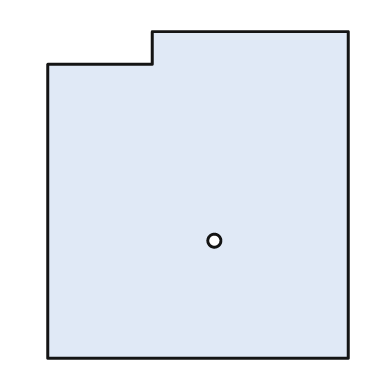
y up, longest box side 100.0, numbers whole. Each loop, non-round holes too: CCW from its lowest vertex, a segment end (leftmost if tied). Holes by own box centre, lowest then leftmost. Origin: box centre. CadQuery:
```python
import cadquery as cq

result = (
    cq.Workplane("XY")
    .moveTo(-46.0, -50.0)
    .lineTo(46.0, -50.0)
    .lineTo(46.0, 50.0)
    .lineTo(-14.0, 50.0)
    .lineTo(-14.0, 40.0)
    .lineTo(-46.0, 40.0)
    .close()
    .moveTo(5.0, -14.0)
    .circle(2.0)
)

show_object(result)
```